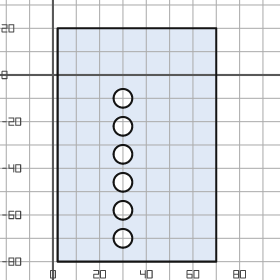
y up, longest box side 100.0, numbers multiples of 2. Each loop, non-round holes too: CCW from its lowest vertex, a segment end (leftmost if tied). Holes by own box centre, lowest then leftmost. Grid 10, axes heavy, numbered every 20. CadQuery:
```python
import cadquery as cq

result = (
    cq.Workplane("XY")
    .moveTo(2.0, -80.0)
    .lineTo(70.0, -80.0)
    .lineTo(70.0, 20.0)
    .lineTo(2.0, 20.0)
    .close()
    .moveTo(30.0, -70.0)
    .circle(4.0)
    .moveTo(30.0, -58.0)
    .circle(4.0)
    .moveTo(30.0, -46.0)
    .circle(4.0)
    .moveTo(30.0, -34.0)
    .circle(4.0)
    .moveTo(30.0, -22.0)
    .circle(4.0)
    .moveTo(30.0, -10.0)
    .circle(4.0)
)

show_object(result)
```